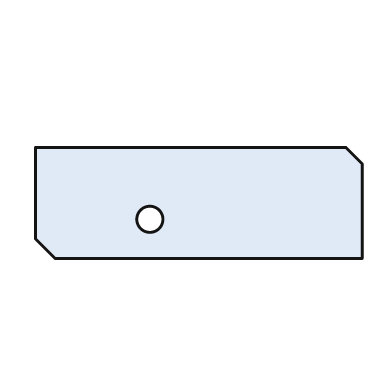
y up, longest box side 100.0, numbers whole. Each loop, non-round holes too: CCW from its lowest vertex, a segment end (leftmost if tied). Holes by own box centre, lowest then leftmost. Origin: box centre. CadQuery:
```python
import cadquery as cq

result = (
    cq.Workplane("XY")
    .moveTo(-44.0, -17.0)
    .lineTo(50.0, -17.0)
    .lineTo(50.0, 12.0)
    .lineTo(45.0, 17.0)
    .lineTo(-50.0, 17.0)
    .lineTo(-50.0, -11.0)
    .close()
    .moveTo(-15.0, -5.0)
    .circle(4.0)
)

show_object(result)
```